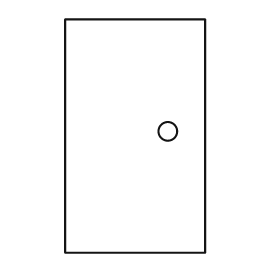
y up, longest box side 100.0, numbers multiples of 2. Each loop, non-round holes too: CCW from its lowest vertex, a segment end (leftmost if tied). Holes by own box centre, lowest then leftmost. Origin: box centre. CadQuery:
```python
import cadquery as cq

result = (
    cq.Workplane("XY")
    .moveTo(-30.0, -50.0)
    .lineTo(30.0, -50.0)
    .lineTo(30.0, 50.0)
    .lineTo(-30.0, 50.0)
    .close()
    .moveTo(14.0, 2.0)
    .circle(4.0)
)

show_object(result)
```